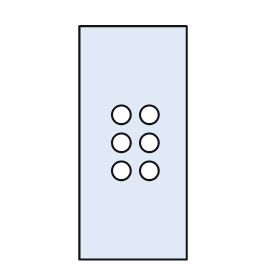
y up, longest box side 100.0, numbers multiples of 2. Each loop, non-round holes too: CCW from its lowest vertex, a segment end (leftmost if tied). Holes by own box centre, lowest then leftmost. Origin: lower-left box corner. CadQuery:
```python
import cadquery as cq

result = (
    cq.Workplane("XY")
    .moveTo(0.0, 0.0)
    .lineTo(46.0, 0.0)
    .lineTo(46.0, 100.0)
    .lineTo(0.0, 100.0)
    .close()
    .moveTo(18.0, 38.0)
    .circle(4.0)
    .moveTo(30.0, 38.0)
    .circle(4.0)
    .moveTo(18.0, 50.0)
    .circle(4.0)
    .moveTo(30.0, 50.0)
    .circle(4.0)
    .moveTo(18.0, 62.0)
    .circle(4.0)
    .moveTo(30.0, 62.0)
    .circle(4.0)
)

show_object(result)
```